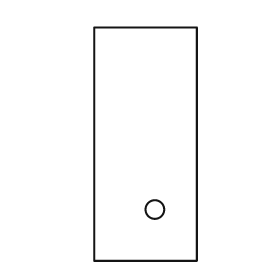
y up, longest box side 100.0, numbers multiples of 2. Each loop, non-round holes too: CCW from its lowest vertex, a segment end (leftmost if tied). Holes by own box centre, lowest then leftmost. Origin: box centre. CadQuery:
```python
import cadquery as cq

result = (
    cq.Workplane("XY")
    .moveTo(-22.0, -50.0)
    .lineTo(22.0, -50.0)
    .lineTo(22.0, 50.0)
    .lineTo(-22.0, 50.0)
    .close()
    .moveTo(4.0, -28.0)
    .circle(4.0)
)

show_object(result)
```